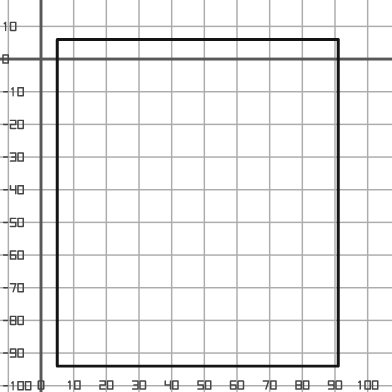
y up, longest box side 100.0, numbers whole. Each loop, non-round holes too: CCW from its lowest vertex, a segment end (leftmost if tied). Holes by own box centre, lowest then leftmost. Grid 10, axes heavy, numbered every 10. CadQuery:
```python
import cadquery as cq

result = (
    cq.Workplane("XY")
    .moveTo(5.0, -94.0)
    .lineTo(91.0, -94.0)
    .lineTo(91.0, 6.0)
    .lineTo(5.0, 6.0)
    .close()
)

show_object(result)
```